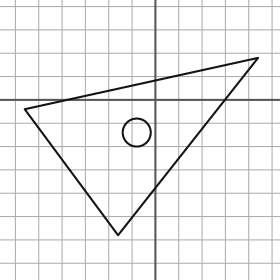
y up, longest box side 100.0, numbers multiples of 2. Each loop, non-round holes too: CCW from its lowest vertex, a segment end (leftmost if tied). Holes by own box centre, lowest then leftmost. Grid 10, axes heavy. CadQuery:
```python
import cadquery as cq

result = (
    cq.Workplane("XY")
    .moveTo(-16.0, -58.0)
    .lineTo(44.0, 18.0)
    .lineTo(-56.0, -4.0)
    .close()
    .moveTo(-8.0, -14.0)
    .circle(6.0)
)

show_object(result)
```